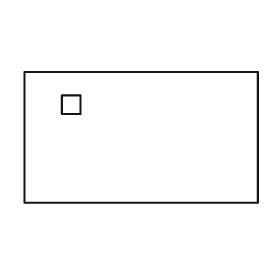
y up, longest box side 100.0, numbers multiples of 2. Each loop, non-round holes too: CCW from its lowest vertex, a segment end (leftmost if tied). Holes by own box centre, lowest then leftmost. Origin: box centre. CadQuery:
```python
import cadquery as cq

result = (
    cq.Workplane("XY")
    .moveTo(-50.0, -28.0)
    .lineTo(50.0, -28.0)
    .lineTo(50.0, 28.0)
    .lineTo(-50.0, 28.0)
    .close()
    .moveTo(-34.0, 10.0)
    .lineTo(-26.0, 10.0)
    .lineTo(-26.0, 18.0)
    .lineTo(-34.0, 18.0)
    .close()
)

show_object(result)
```